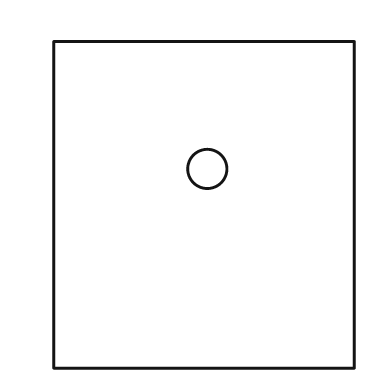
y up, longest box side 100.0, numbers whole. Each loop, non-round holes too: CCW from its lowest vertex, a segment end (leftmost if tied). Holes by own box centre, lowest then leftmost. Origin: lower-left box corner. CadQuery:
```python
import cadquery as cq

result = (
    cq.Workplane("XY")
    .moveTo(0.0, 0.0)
    .lineTo(92.0, 0.0)
    .lineTo(92.0, 100.0)
    .lineTo(0.0, 100.0)
    .close()
    .moveTo(47.0, 61.0)
    .circle(6.0)
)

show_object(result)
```